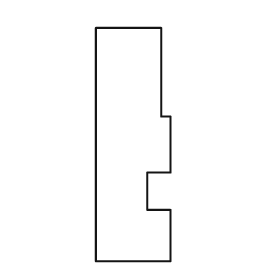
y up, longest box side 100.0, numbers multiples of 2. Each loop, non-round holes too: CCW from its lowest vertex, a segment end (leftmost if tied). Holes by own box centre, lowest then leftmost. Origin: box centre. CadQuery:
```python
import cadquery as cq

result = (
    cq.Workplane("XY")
    .moveTo(-16.0, -50.0)
    .lineTo(16.0, -50.0)
    .lineTo(16.0, -28.0)
    .lineTo(6.0, -28.0)
    .lineTo(6.0, -12.0)
    .lineTo(16.0, -12.0)
    .lineTo(16.0, 12.0)
    .lineTo(12.0, 12.0)
    .lineTo(12.0, 50.0)
    .lineTo(-16.0, 50.0)
    .close()
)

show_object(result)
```